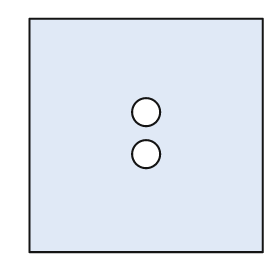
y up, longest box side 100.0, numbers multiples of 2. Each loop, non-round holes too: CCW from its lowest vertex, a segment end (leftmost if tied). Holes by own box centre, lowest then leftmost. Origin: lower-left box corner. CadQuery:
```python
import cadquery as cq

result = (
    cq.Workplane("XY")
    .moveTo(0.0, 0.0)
    .lineTo(100.0, 0.0)
    .lineTo(100.0, 100.0)
    .lineTo(0.0, 100.0)
    .close()
    .moveTo(50.0, 42.0)
    .circle(6.0)
    .moveTo(50.0, 60.0)
    .circle(6.0)
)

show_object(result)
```